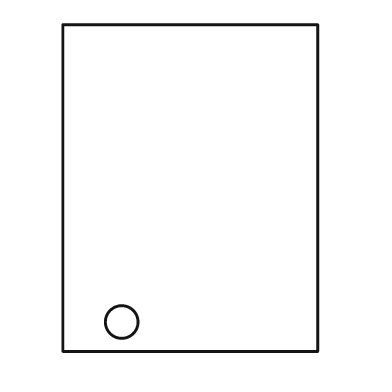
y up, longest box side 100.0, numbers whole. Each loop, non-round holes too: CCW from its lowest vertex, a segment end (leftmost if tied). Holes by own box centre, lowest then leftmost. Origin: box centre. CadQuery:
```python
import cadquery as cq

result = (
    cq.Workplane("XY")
    .moveTo(-39.0, -50.0)
    .lineTo(39.0, -50.0)
    .lineTo(39.0, 50.0)
    .lineTo(-39.0, 50.0)
    .close()
    .moveTo(-21.0, -41.0)
    .circle(5.0)
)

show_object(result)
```